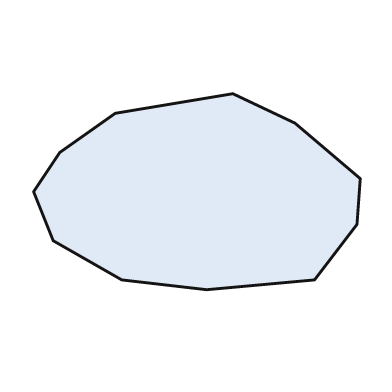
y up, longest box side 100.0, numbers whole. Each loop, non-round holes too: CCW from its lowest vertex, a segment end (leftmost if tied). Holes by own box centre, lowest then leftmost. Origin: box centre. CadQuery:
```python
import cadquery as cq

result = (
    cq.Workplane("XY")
    .moveTo(3.0, -30.0)
    .lineTo(36.0, -27.0)
    .lineTo(49.0, -10.0)
    .lineTo(50.0, 4.0)
    .lineTo(30.0, 21.0)
    .lineTo(11.0, 30.0)
    .lineTo(-25.0, 24.0)
    .lineTo(-42.0, 12.0)
    .lineTo(-50.0, 0.0)
    .lineTo(-44.0, -15.0)
    .lineTo(-23.0, -27.0)
    .close()
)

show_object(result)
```